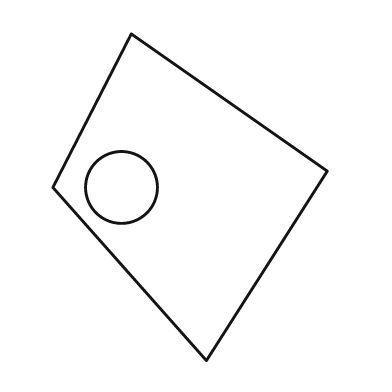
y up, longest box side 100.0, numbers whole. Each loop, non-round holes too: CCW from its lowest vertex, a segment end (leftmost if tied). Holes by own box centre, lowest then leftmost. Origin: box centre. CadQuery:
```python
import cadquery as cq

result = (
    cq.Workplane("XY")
    .moveTo(5.0, -50.0)
    .lineTo(42.0, 8.0)
    .lineTo(-18.0, 50.0)
    .lineTo(-42.0, 3.0)
    .close()
    .moveTo(-21.0, 3.0)
    .circle(11.0)
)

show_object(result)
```